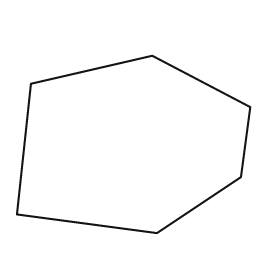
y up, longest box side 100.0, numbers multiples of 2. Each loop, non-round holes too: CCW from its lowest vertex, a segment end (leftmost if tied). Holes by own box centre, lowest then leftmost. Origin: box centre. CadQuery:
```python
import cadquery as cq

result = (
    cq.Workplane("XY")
    .moveTo(10.0, -38.0)
    .lineTo(46.0, -14.0)
    .lineTo(50.0, 16.0)
    .lineTo(8.0, 38.0)
    .lineTo(-44.0, 26.0)
    .lineTo(-50.0, -30.0)
    .close()
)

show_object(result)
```